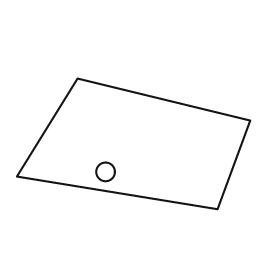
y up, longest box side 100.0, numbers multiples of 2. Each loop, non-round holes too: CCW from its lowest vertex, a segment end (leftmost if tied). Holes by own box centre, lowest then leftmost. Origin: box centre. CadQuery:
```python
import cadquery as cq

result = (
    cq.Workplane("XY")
    .moveTo(36.0, -28.0)
    .lineTo(50.0, 10.0)
    .lineTo(-24.0, 28.0)
    .lineTo(-50.0, -14.0)
    .close()
    .moveTo(-12.0, -12.0)
    .circle(4.0)
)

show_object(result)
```